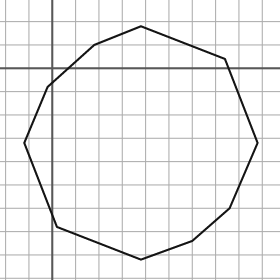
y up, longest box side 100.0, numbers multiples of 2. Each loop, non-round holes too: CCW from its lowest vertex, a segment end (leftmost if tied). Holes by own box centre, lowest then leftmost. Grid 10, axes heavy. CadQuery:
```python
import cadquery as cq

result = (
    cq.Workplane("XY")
    .moveTo(38.0, -82.0)
    .lineTo(60.0, -74.0)
    .lineTo(76.0, -60.0)
    .lineTo(88.0, -32.0)
    .lineTo(74.0, 4.0)
    .lineTo(38.0, 18.0)
    .lineTo(18.0, 10.0)
    .lineTo(-2.0, -8.0)
    .lineTo(-12.0, -32.0)
    .lineTo(2.0, -68.0)
    .close()
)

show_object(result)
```